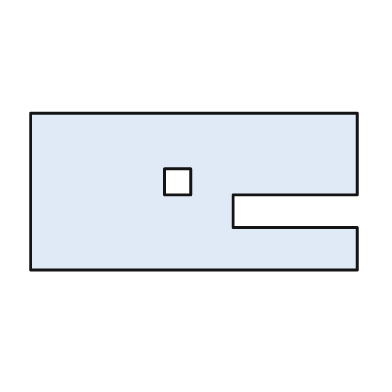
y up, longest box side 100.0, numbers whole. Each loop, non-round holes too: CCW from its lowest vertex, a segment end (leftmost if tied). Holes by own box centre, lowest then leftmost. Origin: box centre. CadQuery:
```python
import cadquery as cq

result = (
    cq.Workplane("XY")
    .moveTo(-50.0, -24.0)
    .lineTo(50.0, -24.0)
    .lineTo(50.0, -11.0)
    .lineTo(12.0, -11.0)
    .lineTo(12.0, -1.0)
    .lineTo(50.0, -1.0)
    .lineTo(50.0, 24.0)
    .lineTo(-50.0, 24.0)
    .close()
    .moveTo(-9.0, -1.0)
    .lineTo(-1.0, -1.0)
    .lineTo(-1.0, 7.0)
    .lineTo(-9.0, 7.0)
    .close()
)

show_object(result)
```